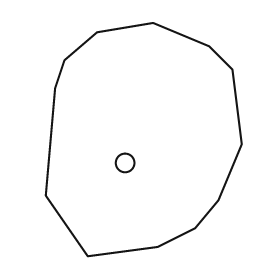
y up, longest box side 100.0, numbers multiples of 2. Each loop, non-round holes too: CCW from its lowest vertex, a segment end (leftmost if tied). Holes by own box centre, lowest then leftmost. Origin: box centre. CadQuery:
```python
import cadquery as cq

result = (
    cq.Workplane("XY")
    .moveTo(-24.0, -50.0)
    .lineTo(6.0, -46.0)
    .lineTo(22.0, -38.0)
    .lineTo(32.0, -26.0)
    .lineTo(42.0, -2.0)
    .lineTo(38.0, 30.0)
    .lineTo(28.0, 40.0)
    .lineTo(4.0, 50.0)
    .lineTo(-20.0, 46.0)
    .lineTo(-34.0, 34.0)
    .lineTo(-38.0, 22.0)
    .lineTo(-42.0, -24.0)
    .close()
    .moveTo(-8.0, -10.0)
    .circle(4.0)
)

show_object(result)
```